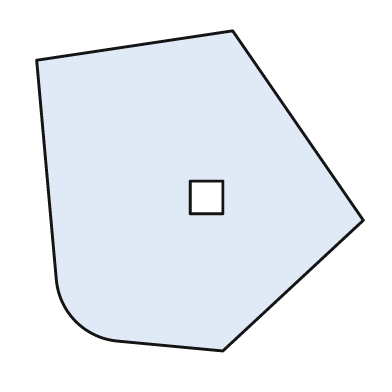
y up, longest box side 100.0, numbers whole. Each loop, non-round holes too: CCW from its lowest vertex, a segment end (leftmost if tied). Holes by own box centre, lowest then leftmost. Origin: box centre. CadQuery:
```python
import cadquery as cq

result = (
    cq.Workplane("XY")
    .moveTo(7.0, -49.0)
    .lineTo(50.0, -9.0)
    .lineTo(10.0, 49.0)
    .lineTo(-50.0, 40.0)
    .lineTo(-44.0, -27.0)
    .threePointArc((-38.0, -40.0), (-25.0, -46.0))
    .close()
    .moveTo(-3.0, -7.0)
    .lineTo(7.0, -7.0)
    .lineTo(7.0, 3.0)
    .lineTo(-3.0, 3.0)
    .close()
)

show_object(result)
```